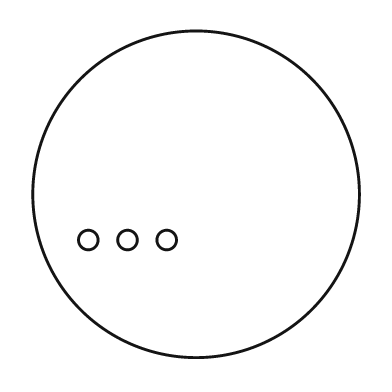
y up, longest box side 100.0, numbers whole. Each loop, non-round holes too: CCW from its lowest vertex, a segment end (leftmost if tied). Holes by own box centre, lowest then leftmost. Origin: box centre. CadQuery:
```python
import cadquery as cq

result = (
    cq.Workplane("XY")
    .moveTo(0.0, 0.0)
    .circle(50.0)
    .moveTo(-33.0, -14.0)
    .circle(3.0)
    .moveTo(-21.0, -14.0)
    .circle(3.0)
    .moveTo(-9.0, -14.0)
    .circle(3.0)
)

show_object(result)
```